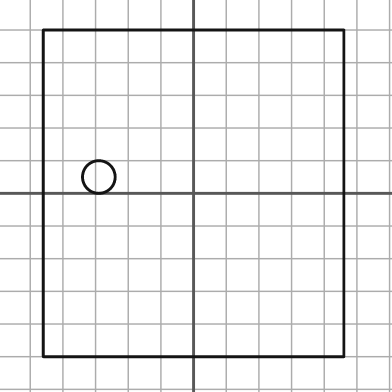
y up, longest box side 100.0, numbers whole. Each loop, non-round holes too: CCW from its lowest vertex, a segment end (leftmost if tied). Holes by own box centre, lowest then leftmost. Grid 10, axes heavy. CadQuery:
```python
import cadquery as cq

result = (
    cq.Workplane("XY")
    .moveTo(-46.0, -50.0)
    .lineTo(46.0, -50.0)
    .lineTo(46.0, 50.0)
    .lineTo(-46.0, 50.0)
    .close()
    .moveTo(-29.0, 5.0)
    .circle(5.0)
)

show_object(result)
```